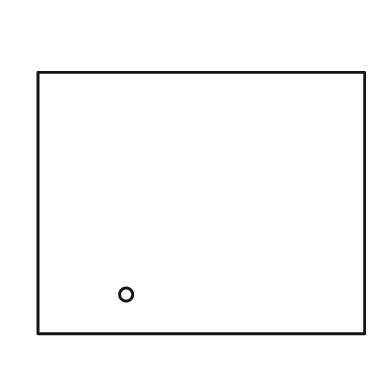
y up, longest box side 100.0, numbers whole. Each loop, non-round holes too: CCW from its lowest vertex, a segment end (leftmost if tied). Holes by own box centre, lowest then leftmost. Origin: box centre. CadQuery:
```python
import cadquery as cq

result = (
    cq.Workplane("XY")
    .moveTo(-50.0, -40.0)
    .lineTo(50.0, -40.0)
    .lineTo(50.0, 40.0)
    .lineTo(-50.0, 40.0)
    .close()
    .moveTo(-23.0, -28.0)
    .circle(2.0)
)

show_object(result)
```